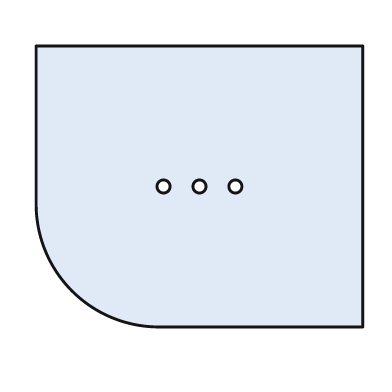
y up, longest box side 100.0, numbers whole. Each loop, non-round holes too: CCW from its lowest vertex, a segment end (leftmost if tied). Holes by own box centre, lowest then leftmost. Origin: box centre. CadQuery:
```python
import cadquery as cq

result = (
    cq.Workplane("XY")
    .moveTo(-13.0, -43.0)
    .lineTo(50.0, -43.0)
    .lineTo(50.0, 43.0)
    .lineTo(-50.0, 43.0)
    .lineTo(-50.0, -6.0)
    .threePointArc((-39.0, -32.0), (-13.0, -43.0))
    .close()
    .moveTo(-11.0, 0.0)
    .circle(2.0)
    .moveTo(0.0, 0.0)
    .circle(2.0)
    .moveTo(11.0, 0.0)
    .circle(2.0)
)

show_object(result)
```